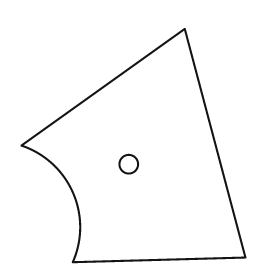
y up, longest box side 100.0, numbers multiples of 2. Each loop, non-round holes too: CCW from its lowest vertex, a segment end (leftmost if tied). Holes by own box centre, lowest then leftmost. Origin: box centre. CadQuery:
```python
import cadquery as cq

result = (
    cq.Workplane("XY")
    .moveTo(-26.0, -50.0)
    .lineTo(48.0, -48.0)
    .lineTo(22.0, 50.0)
    .lineTo(-48.0, 0.0)
    .threePointArc((-26.0, -20.0), (-26.0, -50.0))
    .close()
    .moveTo(-2.0, -8.0)
    .circle(4.0)
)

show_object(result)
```